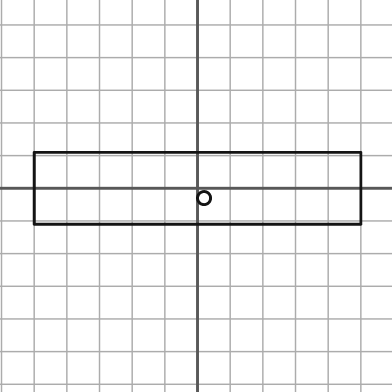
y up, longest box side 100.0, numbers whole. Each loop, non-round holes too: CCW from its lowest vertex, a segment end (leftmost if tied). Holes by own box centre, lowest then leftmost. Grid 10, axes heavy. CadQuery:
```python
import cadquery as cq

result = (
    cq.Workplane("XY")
    .moveTo(-50.0, -11.0)
    .lineTo(50.0, -11.0)
    .lineTo(50.0, 11.0)
    .lineTo(-50.0, 11.0)
    .close()
    .moveTo(2.0, -3.0)
    .circle(2.0)
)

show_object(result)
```